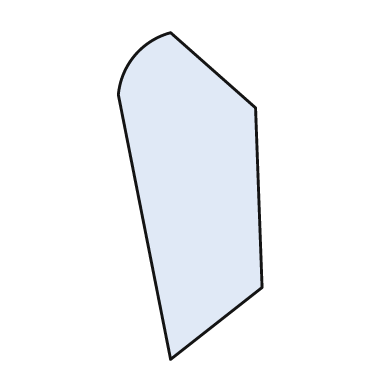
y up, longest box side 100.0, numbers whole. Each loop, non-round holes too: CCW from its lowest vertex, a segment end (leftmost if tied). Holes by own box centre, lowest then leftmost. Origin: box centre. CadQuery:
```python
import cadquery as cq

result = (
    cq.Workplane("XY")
    .moveTo(-6.0, -50.0)
    .lineTo(22.0, -28.0)
    .lineTo(20.0, 27.0)
    .lineTo(-6.0, 50.0)
    .threePointArc((-17.0, 43.0), (-22.0, 31.0))
    .close()
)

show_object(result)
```